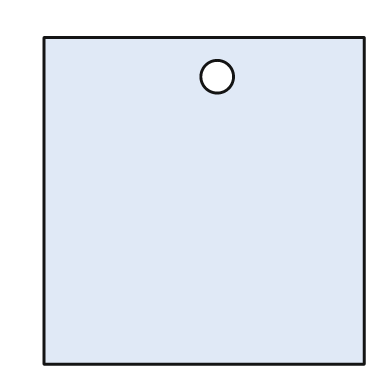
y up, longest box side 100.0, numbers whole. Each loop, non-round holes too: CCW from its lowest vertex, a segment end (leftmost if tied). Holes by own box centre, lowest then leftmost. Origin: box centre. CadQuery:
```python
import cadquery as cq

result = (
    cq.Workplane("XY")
    .moveTo(-49.0, -50.0)
    .lineTo(49.0, -50.0)
    .lineTo(49.0, 50.0)
    .lineTo(-49.0, 50.0)
    .close()
    .moveTo(4.0, 38.0)
    .circle(5.0)
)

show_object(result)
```